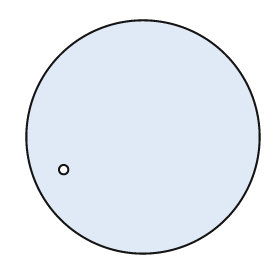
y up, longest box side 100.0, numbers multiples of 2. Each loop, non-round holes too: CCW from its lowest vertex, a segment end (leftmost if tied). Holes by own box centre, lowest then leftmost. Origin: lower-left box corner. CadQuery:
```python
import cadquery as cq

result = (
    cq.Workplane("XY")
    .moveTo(50.0, 50.0)
    .circle(50.0)
    .moveTo(16.0, 36.0)
    .circle(2.0)
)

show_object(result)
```